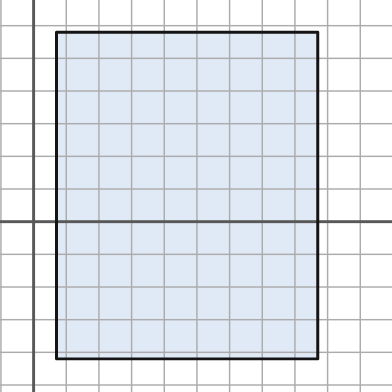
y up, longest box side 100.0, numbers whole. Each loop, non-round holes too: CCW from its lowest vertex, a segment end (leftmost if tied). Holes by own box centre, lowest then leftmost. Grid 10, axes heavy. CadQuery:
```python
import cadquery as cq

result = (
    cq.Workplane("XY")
    .moveTo(7.0, -42.0)
    .lineTo(87.0, -42.0)
    .lineTo(87.0, 58.0)
    .lineTo(7.0, 58.0)
    .close()
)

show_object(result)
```